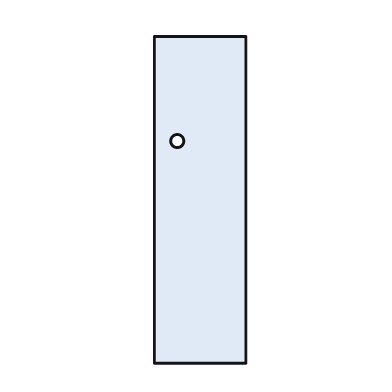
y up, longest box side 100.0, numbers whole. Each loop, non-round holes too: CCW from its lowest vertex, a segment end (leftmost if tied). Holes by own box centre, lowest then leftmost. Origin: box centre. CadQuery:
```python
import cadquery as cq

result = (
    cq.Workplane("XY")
    .moveTo(-14.0, -50.0)
    .lineTo(14.0, -50.0)
    .lineTo(14.0, 50.0)
    .lineTo(-14.0, 50.0)
    .close()
    .moveTo(-7.0, 18.0)
    .circle(2.0)
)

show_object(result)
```